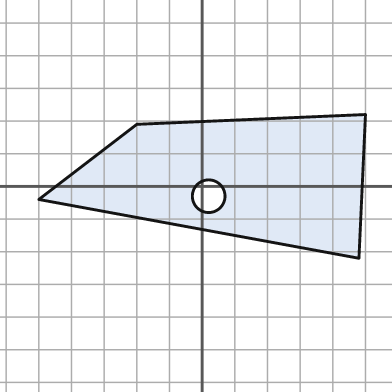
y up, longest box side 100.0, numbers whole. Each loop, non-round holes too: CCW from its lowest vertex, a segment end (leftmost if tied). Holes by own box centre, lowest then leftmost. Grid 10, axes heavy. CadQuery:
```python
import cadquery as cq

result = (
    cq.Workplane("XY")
    .moveTo(48.0, -22.0)
    .lineTo(50.0, 22.0)
    .lineTo(-20.0, 19.0)
    .lineTo(-50.0, -4.0)
    .close()
    .moveTo(2.0, -3.0)
    .circle(5.0)
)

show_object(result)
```